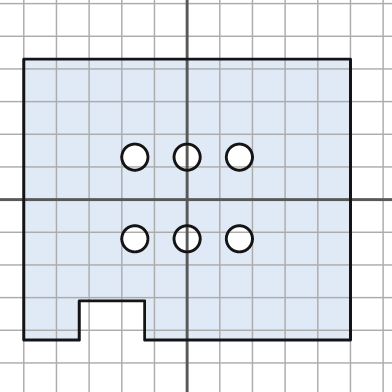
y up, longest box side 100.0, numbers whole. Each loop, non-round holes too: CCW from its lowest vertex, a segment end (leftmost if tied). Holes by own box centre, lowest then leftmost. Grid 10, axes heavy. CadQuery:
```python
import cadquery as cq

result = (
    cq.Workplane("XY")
    .moveTo(-50.0, -43.0)
    .lineTo(-33.0, -43.0)
    .lineTo(-33.0, -31.0)
    .lineTo(-13.0, -31.0)
    .lineTo(-13.0, -43.0)
    .lineTo(50.0, -43.0)
    .lineTo(50.0, 43.0)
    .lineTo(-50.0, 43.0)
    .close()
    .moveTo(-16.0, -12.0)
    .circle(4.0)
    .moveTo(0.0, -12.0)
    .circle(4.0)
    .moveTo(16.0, -12.0)
    .circle(4.0)
    .moveTo(-16.0, 13.0)
    .circle(4.0)
    .moveTo(0.0, 13.0)
    .circle(4.0)
    .moveTo(16.0, 13.0)
    .circle(4.0)
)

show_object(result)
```